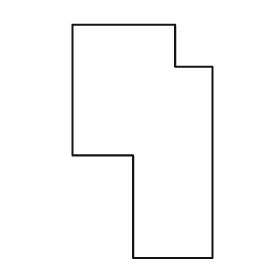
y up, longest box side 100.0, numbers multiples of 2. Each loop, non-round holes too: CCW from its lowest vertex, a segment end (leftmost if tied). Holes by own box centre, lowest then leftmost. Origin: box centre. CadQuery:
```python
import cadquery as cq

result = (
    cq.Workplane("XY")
    .moveTo(-4.0, -50.0)
    .lineTo(30.0, -50.0)
    .lineTo(30.0, 32.0)
    .lineTo(14.0, 32.0)
    .lineTo(14.0, 50.0)
    .lineTo(-30.0, 50.0)
    .lineTo(-30.0, -6.0)
    .lineTo(-4.0, -6.0)
    .close()
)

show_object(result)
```